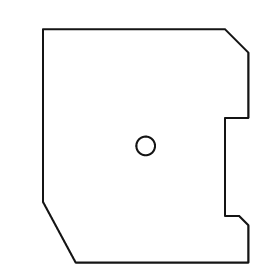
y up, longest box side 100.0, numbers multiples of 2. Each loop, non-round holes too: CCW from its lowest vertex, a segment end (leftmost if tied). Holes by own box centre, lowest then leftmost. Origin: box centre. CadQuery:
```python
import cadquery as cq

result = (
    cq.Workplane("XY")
    .moveTo(-30.0, -50.0)
    .lineTo(44.0, -50.0)
    .lineTo(44.0, -34.0)
    .lineTo(40.0, -30.0)
    .lineTo(34.0, -30.0)
    .lineTo(34.0, 12.0)
    .lineTo(44.0, 12.0)
    .lineTo(44.0, 40.0)
    .lineTo(34.0, 50.0)
    .lineTo(-44.0, 50.0)
    .lineTo(-44.0, -24.0)
    .close()
    .moveTo(0.0, 0.0)
    .circle(4.0)
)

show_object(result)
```